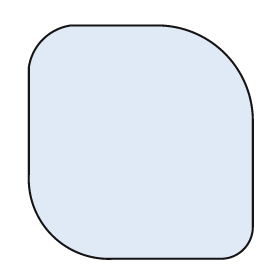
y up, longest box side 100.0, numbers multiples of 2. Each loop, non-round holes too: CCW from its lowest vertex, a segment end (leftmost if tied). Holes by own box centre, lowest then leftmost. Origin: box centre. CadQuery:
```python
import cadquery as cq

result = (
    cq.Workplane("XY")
    .moveTo(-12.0, -50.0)
    .lineTo(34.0, -50.0)
    .threePointArc((44.0, -46.0), (48.0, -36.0))
    .lineTo(48.0, 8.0)
    .threePointArc((36.0, 38.0), (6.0, 50.0))
    .lineTo(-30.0, 50.0)
    .threePointArc((-42.0, 44.0), (-48.0, 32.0))
    .lineTo(-48.0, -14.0)
    .threePointArc((-38.0, -40.0), (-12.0, -50.0))
    .close()
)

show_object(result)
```